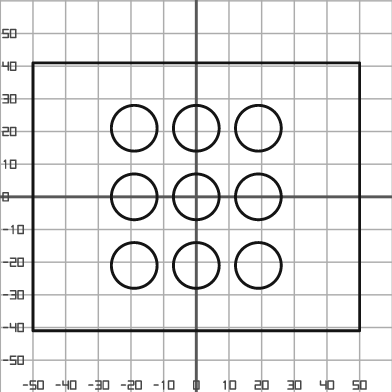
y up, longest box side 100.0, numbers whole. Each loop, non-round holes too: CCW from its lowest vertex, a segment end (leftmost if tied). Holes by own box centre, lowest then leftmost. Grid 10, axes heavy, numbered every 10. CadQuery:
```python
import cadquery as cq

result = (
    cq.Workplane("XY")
    .moveTo(-50.0, -41.0)
    .lineTo(50.0, -41.0)
    .lineTo(50.0, 41.0)
    .lineTo(-50.0, 41.0)
    .close()
    .moveTo(-19.0, -21.0)
    .circle(7.0)
    .moveTo(0.0, -21.0)
    .circle(7.0)
    .moveTo(19.0, -21.0)
    .circle(7.0)
    .moveTo(-19.0, 0.0)
    .circle(7.0)
    .moveTo(0.0, 0.0)
    .circle(7.0)
    .moveTo(19.0, 0.0)
    .circle(7.0)
    .moveTo(-19.0, 21.0)
    .circle(7.0)
    .moveTo(0.0, 21.0)
    .circle(7.0)
    .moveTo(19.0, 21.0)
    .circle(7.0)
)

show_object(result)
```